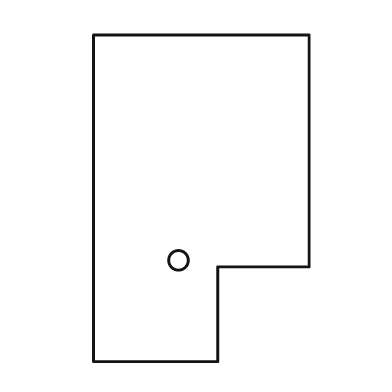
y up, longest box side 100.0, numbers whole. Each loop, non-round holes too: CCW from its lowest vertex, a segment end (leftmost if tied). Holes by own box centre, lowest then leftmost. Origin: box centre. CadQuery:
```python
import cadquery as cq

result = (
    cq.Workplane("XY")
    .moveTo(-33.0, -50.0)
    .lineTo(5.0, -50.0)
    .lineTo(5.0, -21.0)
    .lineTo(33.0, -21.0)
    .lineTo(33.0, 50.0)
    .lineTo(-33.0, 50.0)
    .close()
    .moveTo(-7.0, -19.0)
    .circle(3.0)
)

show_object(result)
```